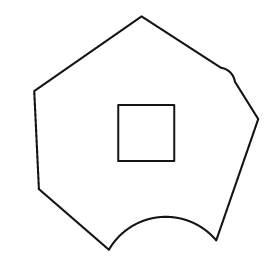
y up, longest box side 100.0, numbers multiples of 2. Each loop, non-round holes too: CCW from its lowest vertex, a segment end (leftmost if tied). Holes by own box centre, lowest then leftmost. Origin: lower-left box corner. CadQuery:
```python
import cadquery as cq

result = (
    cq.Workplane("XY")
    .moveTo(32.0, 0.0)
    .threePointArc((54.0, 14.0), (78.0, 4.0))
    .lineTo(96.0, 56.0)
    .lineTo(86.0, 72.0)
    .threePointArc((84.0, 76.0), (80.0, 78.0))
    .lineTo(46.0, 100.0)
    .lineTo(0.0, 68.0)
    .lineTo(2.0, 26.0)
    .close()
    .moveTo(36.0, 38.0)
    .lineTo(60.0, 38.0)
    .lineTo(60.0, 62.0)
    .lineTo(36.0, 62.0)
    .close()
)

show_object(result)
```